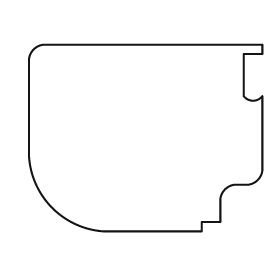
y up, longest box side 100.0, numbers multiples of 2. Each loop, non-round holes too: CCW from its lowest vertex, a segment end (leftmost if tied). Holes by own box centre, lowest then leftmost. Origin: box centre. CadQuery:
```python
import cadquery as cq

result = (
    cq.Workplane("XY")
    .moveTo(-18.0, -40.0)
    .lineTo(24.0, -40.0)
    .lineTo(24.0, -36.0)
    .lineTo(32.0, -36.0)
    .lineTo(32.0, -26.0)
    .threePointArc((34.0, -22.0), (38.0, -20.0))
    .lineTo(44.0, -20.0)
    .threePointArc((48.0, -18.0), (50.0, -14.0))
    .lineTo(50.0, 18.0)
    .threePointArc((46.0, 16.0), (42.0, 18.0))
    .lineTo(42.0, 36.0)
    .lineTo(50.0, 36.0)
    .lineTo(50.0, 40.0)
    .lineTo(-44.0, 40.0)
    .threePointArc((-48.0, 38.0), (-50.0, 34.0))
    .lineTo(-50.0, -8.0)
    .threePointArc((-40.0, -30.0), (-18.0, -40.0))
    .close()
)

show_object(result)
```